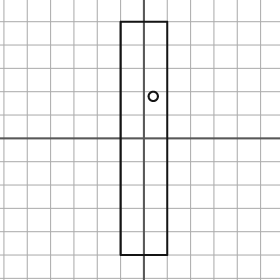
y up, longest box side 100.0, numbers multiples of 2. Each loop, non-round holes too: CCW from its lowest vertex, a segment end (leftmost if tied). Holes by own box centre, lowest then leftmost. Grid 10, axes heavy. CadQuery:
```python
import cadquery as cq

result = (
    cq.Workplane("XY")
    .moveTo(-10.0, -50.0)
    .lineTo(10.0, -50.0)
    .lineTo(10.0, 50.0)
    .lineTo(-10.0, 50.0)
    .close()
    .moveTo(4.0, 18.0)
    .circle(2.0)
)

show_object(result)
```